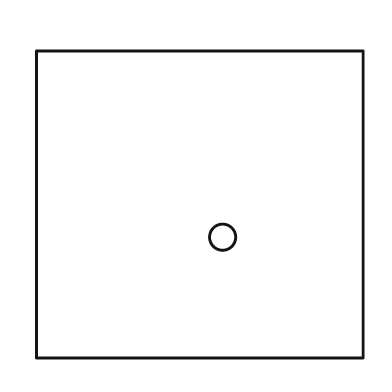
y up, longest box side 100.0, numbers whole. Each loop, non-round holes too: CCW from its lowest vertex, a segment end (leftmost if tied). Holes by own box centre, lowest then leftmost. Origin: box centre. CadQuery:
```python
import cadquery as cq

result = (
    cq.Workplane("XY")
    .moveTo(-50.0, -47.0)
    .lineTo(50.0, -47.0)
    .lineTo(50.0, 47.0)
    .lineTo(-50.0, 47.0)
    .close()
    .moveTo(7.0, -10.0)
    .circle(4.0)
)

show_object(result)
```